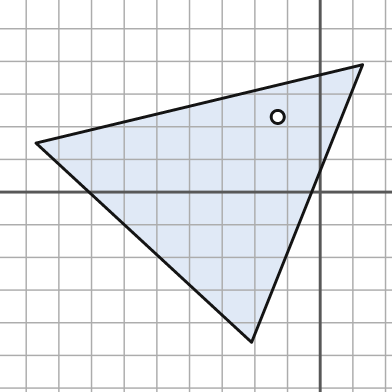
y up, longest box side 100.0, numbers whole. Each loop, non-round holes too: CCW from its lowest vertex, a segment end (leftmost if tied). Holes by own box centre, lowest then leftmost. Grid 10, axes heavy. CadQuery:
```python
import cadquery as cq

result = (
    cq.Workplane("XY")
    .moveTo(-21.0, -46.0)
    .lineTo(13.0, 39.0)
    .lineTo(-87.0, 15.0)
    .close()
    .moveTo(-13.0, 23.0)
    .circle(2.0)
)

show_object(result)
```